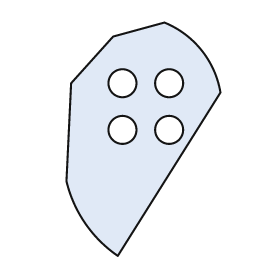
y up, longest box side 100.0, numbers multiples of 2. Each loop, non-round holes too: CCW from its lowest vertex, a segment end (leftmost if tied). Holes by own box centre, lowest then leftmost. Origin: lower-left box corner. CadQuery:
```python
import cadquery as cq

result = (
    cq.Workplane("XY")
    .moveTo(22.0, 0.0)
    .lineTo(66.0, 70.0)
    .threePointArc((58.0, 88.0), (42.0, 100.0))
    .lineTo(20.0, 94.0)
    .lineTo(2.0, 74.0)
    .lineTo(0.0, 32.0)
    .threePointArc((8.0, 14.0), (22.0, 0.0))
    .close()
    .moveTo(24.0, 54.0)
    .circle(6.0)
    .moveTo(44.0, 54.0)
    .circle(6.0)
    .moveTo(24.0, 74.0)
    .circle(6.0)
    .moveTo(44.0, 74.0)
    .circle(6.0)
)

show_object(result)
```